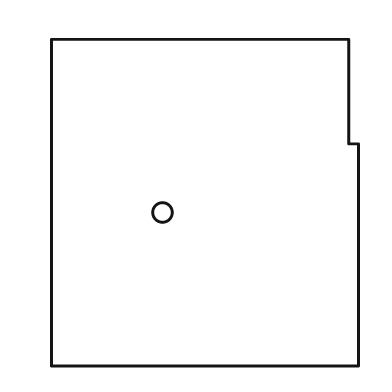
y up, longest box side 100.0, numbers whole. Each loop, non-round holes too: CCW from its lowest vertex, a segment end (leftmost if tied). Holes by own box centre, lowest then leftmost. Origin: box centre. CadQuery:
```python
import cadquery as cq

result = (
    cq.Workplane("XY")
    .moveTo(-47.0, -50.0)
    .lineTo(47.0, -50.0)
    .lineTo(47.0, 18.0)
    .lineTo(44.0, 18.0)
    .lineTo(44.0, 50.0)
    .lineTo(-47.0, 50.0)
    .close()
    .moveTo(-13.0, -3.0)
    .circle(3.0)
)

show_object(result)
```